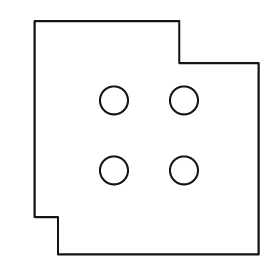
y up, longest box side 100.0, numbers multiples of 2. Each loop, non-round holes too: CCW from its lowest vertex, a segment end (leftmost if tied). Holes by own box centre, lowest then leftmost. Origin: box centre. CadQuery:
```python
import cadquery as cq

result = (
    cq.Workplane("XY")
    .moveTo(-38.0, -50.0)
    .lineTo(48.0, -50.0)
    .lineTo(48.0, 32.0)
    .lineTo(14.0, 32.0)
    .lineTo(14.0, 50.0)
    .lineTo(-48.0, 50.0)
    .lineTo(-48.0, -34.0)
    .lineTo(-38.0, -34.0)
    .close()
    .moveTo(-14.0, -14.0)
    .circle(6.0)
    .moveTo(16.0, -14.0)
    .circle(6.0)
    .moveTo(-14.0, 16.0)
    .circle(6.0)
    .moveTo(16.0, 16.0)
    .circle(6.0)
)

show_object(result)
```